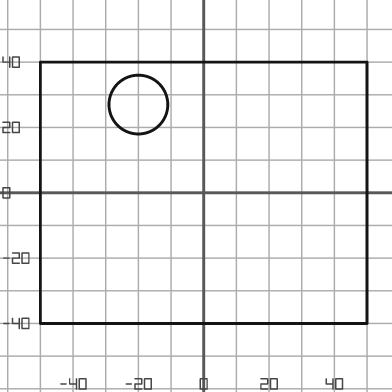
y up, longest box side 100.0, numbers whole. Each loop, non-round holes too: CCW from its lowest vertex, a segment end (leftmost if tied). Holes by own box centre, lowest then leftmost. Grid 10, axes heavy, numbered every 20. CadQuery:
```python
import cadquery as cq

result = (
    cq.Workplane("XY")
    .moveTo(-50.0, -40.0)
    .lineTo(50.0, -40.0)
    .lineTo(50.0, 40.0)
    .lineTo(-50.0, 40.0)
    .close()
    .moveTo(-20.0, 27.0)
    .circle(9.0)
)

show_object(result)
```